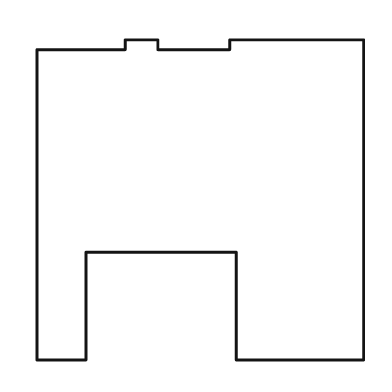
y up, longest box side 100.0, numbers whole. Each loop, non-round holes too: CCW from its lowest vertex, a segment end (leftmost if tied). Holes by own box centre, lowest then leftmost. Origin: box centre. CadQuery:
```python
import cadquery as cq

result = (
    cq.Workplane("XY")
    .moveTo(-50.0, -49.0)
    .lineTo(-35.0, -49.0)
    .lineTo(-35.0, -16.0)
    .lineTo(11.0, -16.0)
    .lineTo(11.0, -49.0)
    .lineTo(50.0, -49.0)
    .lineTo(50.0, 49.0)
    .lineTo(9.0, 49.0)
    .lineTo(9.0, 46.0)
    .lineTo(-13.0, 46.0)
    .lineTo(-13.0, 49.0)
    .lineTo(-23.0, 49.0)
    .lineTo(-23.0, 46.0)
    .lineTo(-50.0, 46.0)
    .close()
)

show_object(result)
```